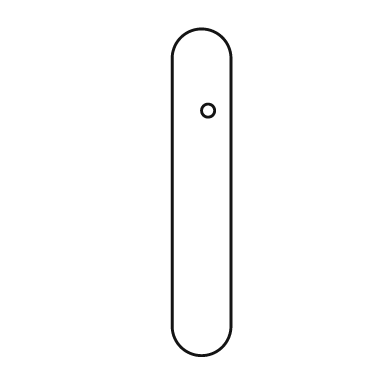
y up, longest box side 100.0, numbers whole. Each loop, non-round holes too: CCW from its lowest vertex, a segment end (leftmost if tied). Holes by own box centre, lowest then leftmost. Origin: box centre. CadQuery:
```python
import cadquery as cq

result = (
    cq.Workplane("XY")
    .moveTo(-9.0, -41.0)
    .threePointArc((0.0, -50.0), (9.0, -41.0))
    .lineTo(9.0, 41.0)
    .threePointArc((0.0, 50.0), (-9.0, 41.0))
    .close()
    .moveTo(2.0, 25.0)
    .circle(2.0)
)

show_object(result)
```